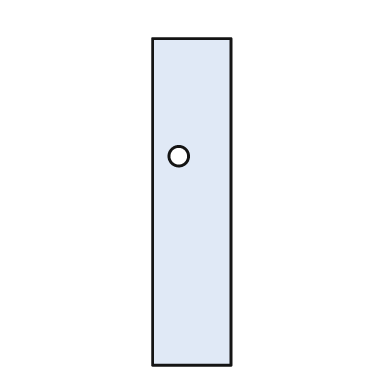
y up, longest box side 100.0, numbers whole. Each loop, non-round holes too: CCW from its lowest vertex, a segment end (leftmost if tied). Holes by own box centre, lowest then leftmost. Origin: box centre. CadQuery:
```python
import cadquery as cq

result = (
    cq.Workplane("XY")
    .moveTo(-12.0, -50.0)
    .lineTo(12.0, -50.0)
    .lineTo(12.0, 50.0)
    .lineTo(-12.0, 50.0)
    .close()
    .moveTo(-4.0, 14.0)
    .circle(3.0)
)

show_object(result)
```